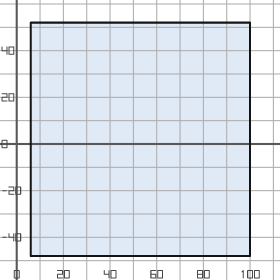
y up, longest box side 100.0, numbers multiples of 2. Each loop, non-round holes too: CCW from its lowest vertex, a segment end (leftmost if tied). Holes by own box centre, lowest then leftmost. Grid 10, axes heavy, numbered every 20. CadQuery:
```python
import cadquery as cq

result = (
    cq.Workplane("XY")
    .moveTo(6.0, -48.0)
    .lineTo(100.0, -48.0)
    .lineTo(100.0, 52.0)
    .lineTo(6.0, 52.0)
    .close()
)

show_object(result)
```